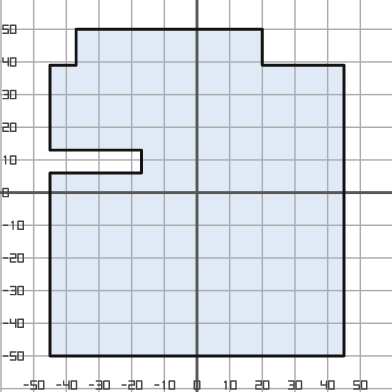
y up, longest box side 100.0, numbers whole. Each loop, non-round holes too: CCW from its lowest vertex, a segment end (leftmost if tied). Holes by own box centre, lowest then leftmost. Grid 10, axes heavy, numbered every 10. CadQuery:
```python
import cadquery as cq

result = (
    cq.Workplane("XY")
    .moveTo(-45.0, -50.0)
    .lineTo(45.0, -50.0)
    .lineTo(45.0, 39.0)
    .lineTo(20.0, 39.0)
    .lineTo(20.0, 50.0)
    .lineTo(-37.0, 50.0)
    .lineTo(-37.0, 39.0)
    .lineTo(-45.0, 39.0)
    .lineTo(-45.0, 13.0)
    .lineTo(-17.0, 13.0)
    .lineTo(-17.0, 6.0)
    .lineTo(-45.0, 6.0)
    .close()
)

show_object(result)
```